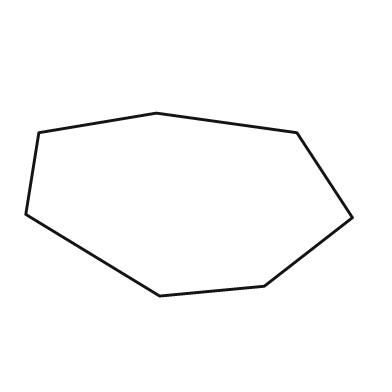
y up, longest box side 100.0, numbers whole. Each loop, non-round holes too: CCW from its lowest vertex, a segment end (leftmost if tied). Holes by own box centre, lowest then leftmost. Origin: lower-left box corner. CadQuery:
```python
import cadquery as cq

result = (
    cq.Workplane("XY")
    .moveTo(41.0, 0.0)
    .lineTo(73.0, 3.0)
    .lineTo(100.0, 24.0)
    .lineTo(83.0, 50.0)
    .lineTo(40.0, 56.0)
    .lineTo(4.0, 50.0)
    .lineTo(0.0, 25.0)
    .close()
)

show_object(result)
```